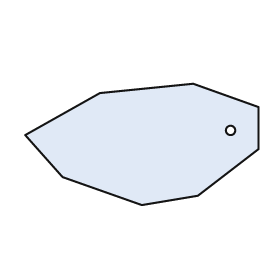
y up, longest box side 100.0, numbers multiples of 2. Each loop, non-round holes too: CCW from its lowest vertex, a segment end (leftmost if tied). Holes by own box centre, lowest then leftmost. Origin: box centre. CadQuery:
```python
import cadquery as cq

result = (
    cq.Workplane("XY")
    .moveTo(0.0, -26.0)
    .lineTo(24.0, -22.0)
    .lineTo(50.0, -2.0)
    .lineTo(50.0, 16.0)
    .lineTo(22.0, 26.0)
    .lineTo(-18.0, 22.0)
    .lineTo(-50.0, 4.0)
    .lineTo(-34.0, -14.0)
    .close()
    .moveTo(38.0, 6.0)
    .circle(2.0)
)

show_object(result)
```